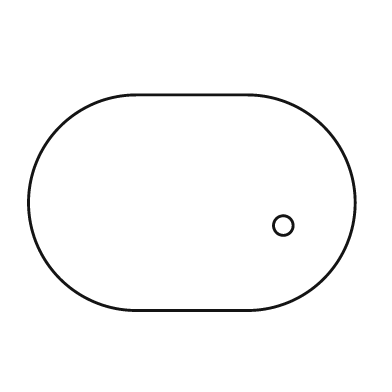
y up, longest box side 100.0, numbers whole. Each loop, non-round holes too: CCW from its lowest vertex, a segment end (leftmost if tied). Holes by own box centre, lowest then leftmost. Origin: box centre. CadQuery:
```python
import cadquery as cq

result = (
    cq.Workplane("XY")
    .moveTo(-17.0, -33.0)
    .lineTo(17.0, -33.0)
    .threePointArc((50.0, 0.0), (17.0, 33.0))
    .lineTo(-17.0, 33.0)
    .threePointArc((-50.0, 0.0), (-17.0, -33.0))
    .close()
    .moveTo(28.0, -7.0)
    .circle(3.0)
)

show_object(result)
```